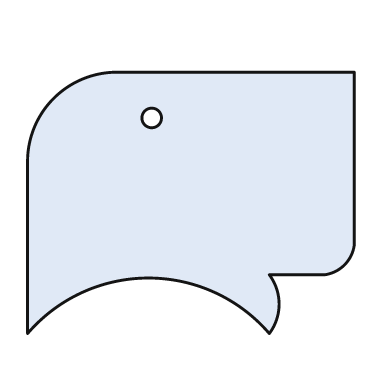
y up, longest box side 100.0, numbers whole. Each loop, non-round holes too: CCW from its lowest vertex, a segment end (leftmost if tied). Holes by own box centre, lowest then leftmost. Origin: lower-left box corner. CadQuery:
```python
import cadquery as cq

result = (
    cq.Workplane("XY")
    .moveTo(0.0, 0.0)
    .threePointArc((37.0, 17.0), (74.0, 0.0))
    .threePointArc((77.0, 9.0), (74.0, 18.0))
    .lineTo(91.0, 18.0)
    .threePointArc((97.0, 21.0), (100.0, 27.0))
    .lineTo(100.0, 80.0)
    .lineTo(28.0, 80.0)
    .threePointArc((8.0, 72.0), (0.0, 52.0))
    .close()
    .moveTo(38.0, 66.0)
    .circle(3.0)
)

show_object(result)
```